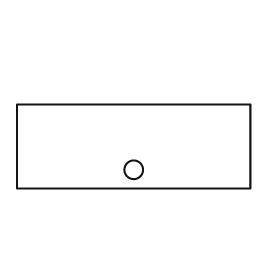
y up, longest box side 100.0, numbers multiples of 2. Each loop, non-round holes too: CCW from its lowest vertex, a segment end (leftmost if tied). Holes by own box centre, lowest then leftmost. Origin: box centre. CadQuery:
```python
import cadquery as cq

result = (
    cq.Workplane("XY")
    .moveTo(-50.0, -18.0)
    .lineTo(50.0, -18.0)
    .lineTo(50.0, 18.0)
    .lineTo(-50.0, 18.0)
    .close()
    .moveTo(0.0, -10.0)
    .circle(4.0)
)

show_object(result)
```